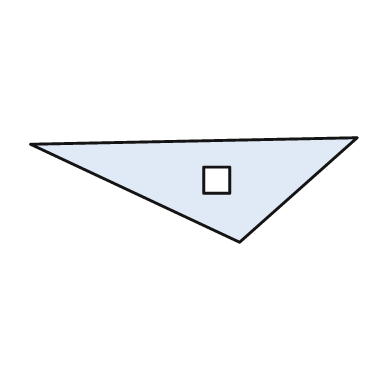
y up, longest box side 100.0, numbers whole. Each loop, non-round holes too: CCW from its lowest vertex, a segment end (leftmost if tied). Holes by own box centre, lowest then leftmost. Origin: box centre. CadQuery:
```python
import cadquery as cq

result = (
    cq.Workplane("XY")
    .moveTo(14.0, -16.0)
    .lineTo(50.0, 16.0)
    .lineTo(-50.0, 14.0)
    .close()
    .moveTo(3.0, -1.0)
    .lineTo(11.0, -1.0)
    .lineTo(11.0, 7.0)
    .lineTo(3.0, 7.0)
    .close()
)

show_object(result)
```